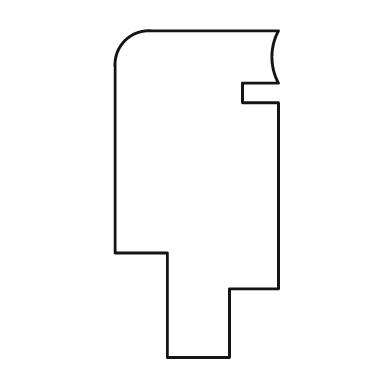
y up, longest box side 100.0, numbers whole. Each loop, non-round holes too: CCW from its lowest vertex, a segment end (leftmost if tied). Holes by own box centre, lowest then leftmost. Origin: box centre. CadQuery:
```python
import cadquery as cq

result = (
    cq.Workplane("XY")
    .moveTo(-9.0, -50.0)
    .lineTo(10.0, -50.0)
    .lineTo(10.0, -29.0)
    .lineTo(25.0, -29.0)
    .lineTo(25.0, 28.0)
    .lineTo(14.0, 28.0)
    .lineTo(14.0, 34.0)
    .lineTo(25.0, 34.0)
    .threePointArc((23.0, 42.0), (25.0, 50.0))
    .lineTo(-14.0, 50.0)
    .threePointArc((-22.0, 47.0), (-25.0, 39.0))
    .lineTo(-25.0, -18.0)
    .lineTo(-9.0, -18.0)
    .close()
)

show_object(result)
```